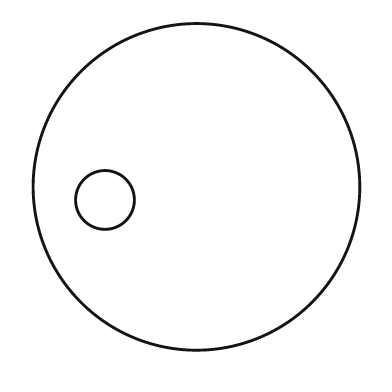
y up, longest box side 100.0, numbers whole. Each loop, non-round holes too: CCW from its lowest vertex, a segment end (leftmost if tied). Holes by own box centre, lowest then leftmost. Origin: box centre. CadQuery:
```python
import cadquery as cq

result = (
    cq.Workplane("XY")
    .moveTo(0.0, 0.0)
    .circle(50.0)
    .moveTo(-28.0, -4.0)
    .circle(9.0)
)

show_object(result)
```